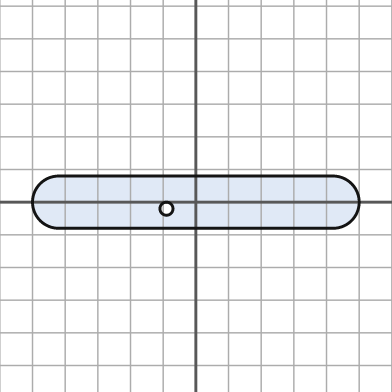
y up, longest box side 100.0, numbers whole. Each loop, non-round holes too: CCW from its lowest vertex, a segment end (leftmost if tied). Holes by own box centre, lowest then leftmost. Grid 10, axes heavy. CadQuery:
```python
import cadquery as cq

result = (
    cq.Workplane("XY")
    .moveTo(-42.0, -8.0)
    .lineTo(42.0, -8.0)
    .threePointArc((50.0, 0.0), (42.0, 8.0))
    .lineTo(-42.0, 8.0)
    .threePointArc((-50.0, 0.0), (-42.0, -8.0))
    .close()
    .moveTo(-9.0, -2.0)
    .circle(2.0)
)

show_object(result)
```